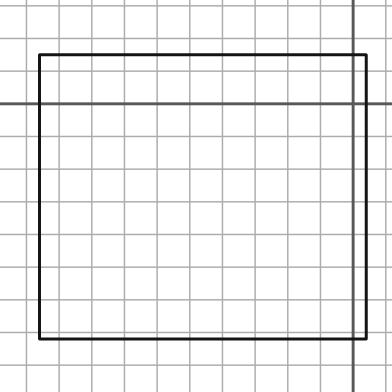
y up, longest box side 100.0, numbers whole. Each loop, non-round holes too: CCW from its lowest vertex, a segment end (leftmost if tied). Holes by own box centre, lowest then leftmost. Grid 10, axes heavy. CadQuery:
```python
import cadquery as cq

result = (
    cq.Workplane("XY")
    .moveTo(-96.0, -72.0)
    .lineTo(4.0, -72.0)
    .lineTo(4.0, 15.0)
    .lineTo(-96.0, 15.0)
    .close()
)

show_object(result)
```